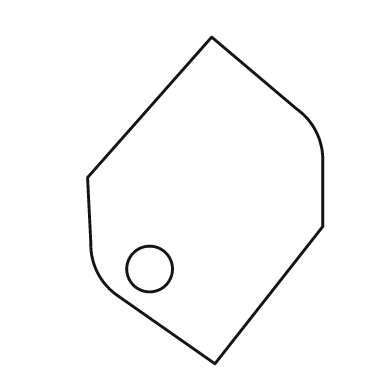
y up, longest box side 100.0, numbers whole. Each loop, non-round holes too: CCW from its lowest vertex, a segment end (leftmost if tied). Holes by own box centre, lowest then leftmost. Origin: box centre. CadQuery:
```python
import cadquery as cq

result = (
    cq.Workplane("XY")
    .moveTo(3.0, -50.0)
    .lineTo(36.0, -8.0)
    .lineTo(36.0, 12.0)
    .threePointArc((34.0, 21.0), (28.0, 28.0))
    .lineTo(2.0, 50.0)
    .lineTo(-36.0, 7.0)
    .lineTo(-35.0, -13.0)
    .threePointArc((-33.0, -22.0), (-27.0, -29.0))
    .close()
    .moveTo(-17.0, -21.0)
    .circle(7.0)
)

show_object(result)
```